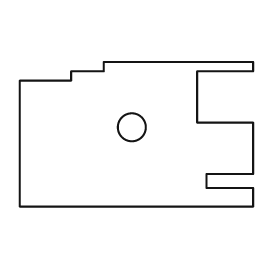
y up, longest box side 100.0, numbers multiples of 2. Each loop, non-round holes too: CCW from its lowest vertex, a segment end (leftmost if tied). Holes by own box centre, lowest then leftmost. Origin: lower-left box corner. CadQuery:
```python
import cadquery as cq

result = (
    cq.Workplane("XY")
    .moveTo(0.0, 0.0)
    .lineTo(100.0, 0.0)
    .lineTo(100.0, 8.0)
    .lineTo(80.0, 8.0)
    .lineTo(80.0, 14.0)
    .lineTo(100.0, 14.0)
    .lineTo(100.0, 36.0)
    .lineTo(76.0, 36.0)
    .lineTo(76.0, 58.0)
    .lineTo(100.0, 58.0)
    .lineTo(100.0, 62.0)
    .lineTo(36.0, 62.0)
    .lineTo(36.0, 58.0)
    .lineTo(22.0, 58.0)
    .lineTo(22.0, 54.0)
    .lineTo(0.0, 54.0)
    .close()
    .moveTo(48.0, 34.0)
    .circle(6.0)
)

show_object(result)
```